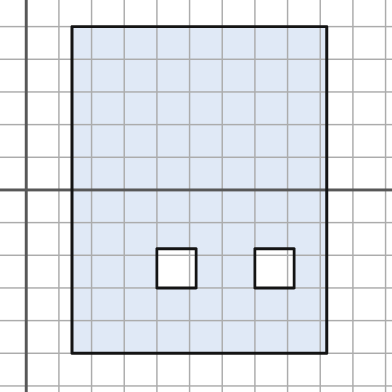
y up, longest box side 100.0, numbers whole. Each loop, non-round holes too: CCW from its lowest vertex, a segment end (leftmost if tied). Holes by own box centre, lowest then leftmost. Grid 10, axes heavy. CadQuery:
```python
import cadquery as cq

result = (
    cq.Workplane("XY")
    .moveTo(14.0, -50.0)
    .lineTo(92.0, -50.0)
    .lineTo(92.0, 50.0)
    .lineTo(14.0, 50.0)
    .close()
    .moveTo(40.0, -30.0)
    .lineTo(52.0, -30.0)
    .lineTo(52.0, -18.0)
    .lineTo(40.0, -18.0)
    .close()
    .moveTo(70.0, -30.0)
    .lineTo(82.0, -30.0)
    .lineTo(82.0, -18.0)
    .lineTo(70.0, -18.0)
    .close()
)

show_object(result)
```